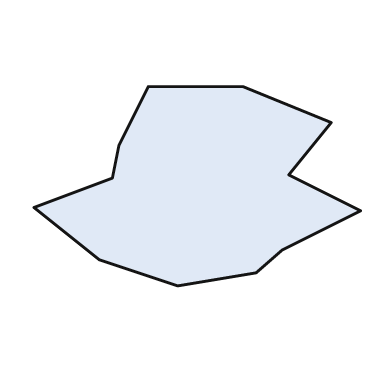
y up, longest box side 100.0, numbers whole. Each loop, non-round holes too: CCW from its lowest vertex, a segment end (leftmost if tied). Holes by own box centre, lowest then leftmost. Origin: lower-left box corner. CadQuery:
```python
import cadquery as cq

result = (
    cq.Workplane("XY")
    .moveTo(44.0, 0.0)
    .lineTo(68.0, 4.0)
    .lineTo(76.0, 11.0)
    .lineTo(100.0, 23.0)
    .lineTo(78.0, 34.0)
    .lineTo(91.0, 50.0)
    .lineTo(64.0, 61.0)
    .lineTo(35.0, 61.0)
    .lineTo(26.0, 43.0)
    .lineTo(24.0, 33.0)
    .lineTo(0.0, 24.0)
    .lineTo(20.0, 8.0)
    .close()
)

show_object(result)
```